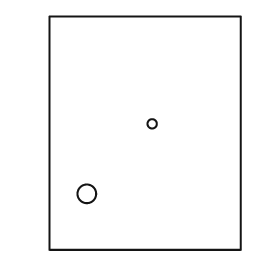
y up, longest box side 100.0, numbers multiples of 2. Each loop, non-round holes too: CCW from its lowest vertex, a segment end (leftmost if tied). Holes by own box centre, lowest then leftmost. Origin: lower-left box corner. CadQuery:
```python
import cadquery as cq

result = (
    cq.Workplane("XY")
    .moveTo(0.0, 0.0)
    .lineTo(82.0, 0.0)
    .lineTo(82.0, 100.0)
    .lineTo(0.0, 100.0)
    .close()
    .moveTo(16.0, 24.0)
    .circle(4.0)
    .moveTo(44.0, 54.0)
    .circle(2.0)
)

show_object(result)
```